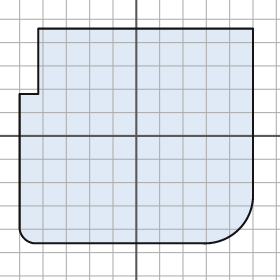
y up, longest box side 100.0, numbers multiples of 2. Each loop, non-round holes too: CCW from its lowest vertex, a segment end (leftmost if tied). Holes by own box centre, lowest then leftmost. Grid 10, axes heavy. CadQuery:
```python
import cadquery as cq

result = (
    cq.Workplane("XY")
    .moveTo(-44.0, -46.0)
    .lineTo(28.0, -46.0)
    .threePointArc((44.0, -40.0), (50.0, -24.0))
    .lineTo(50.0, 46.0)
    .lineTo(-42.0, 46.0)
    .lineTo(-42.0, 18.0)
    .lineTo(-50.0, 18.0)
    .lineTo(-50.0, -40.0)
    .threePointArc((-48.0, -44.0), (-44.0, -46.0))
    .close()
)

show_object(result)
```